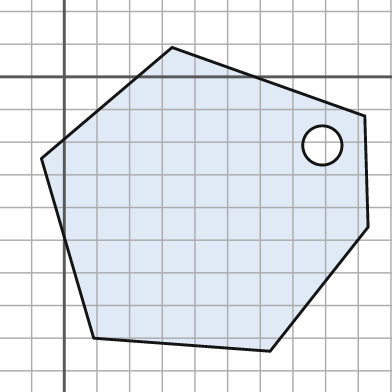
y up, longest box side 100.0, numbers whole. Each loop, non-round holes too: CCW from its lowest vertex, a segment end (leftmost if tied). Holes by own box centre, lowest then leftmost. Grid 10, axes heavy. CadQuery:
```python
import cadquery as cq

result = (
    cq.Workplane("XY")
    .moveTo(63.0, -84.0)
    .lineTo(93.0, -46.0)
    .lineTo(92.0, -12.0)
    .lineTo(33.0, 9.0)
    .lineTo(-7.0, -25.0)
    .lineTo(9.0, -80.0)
    .close()
    .moveTo(79.0, -21.0)
    .circle(6.0)
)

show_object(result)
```